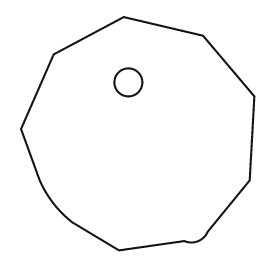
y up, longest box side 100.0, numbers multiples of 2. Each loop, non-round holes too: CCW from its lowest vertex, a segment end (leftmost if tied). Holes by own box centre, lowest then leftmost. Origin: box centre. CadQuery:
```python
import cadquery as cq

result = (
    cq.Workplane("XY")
    .moveTo(-8.0, -50.0)
    .lineTo(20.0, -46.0)
    .threePointArc((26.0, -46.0), (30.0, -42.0))
    .lineTo(48.0, -20.0)
    .lineTo(50.0, 16.0)
    .lineTo(28.0, 42.0)
    .lineTo(-6.0, 50.0)
    .lineTo(-36.0, 34.0)
    .lineTo(-50.0, 2.0)
    .lineTo(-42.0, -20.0)
    .threePointArc((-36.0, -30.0), (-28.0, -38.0))
    .close()
    .moveTo(-4.0, 22.0)
    .circle(6.0)
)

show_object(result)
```